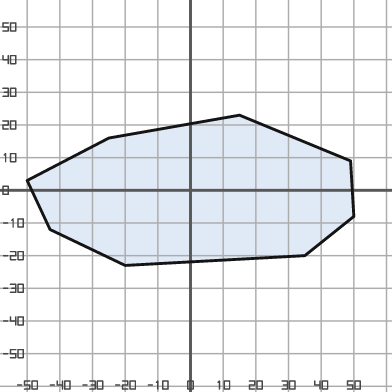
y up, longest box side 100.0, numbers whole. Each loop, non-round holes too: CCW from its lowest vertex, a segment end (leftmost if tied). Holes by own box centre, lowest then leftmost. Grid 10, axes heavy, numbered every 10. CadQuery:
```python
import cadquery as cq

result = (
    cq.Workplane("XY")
    .moveTo(-20.0, -23.0)
    .lineTo(35.0, -20.0)
    .lineTo(50.0, -8.0)
    .lineTo(49.0, 9.0)
    .lineTo(15.0, 23.0)
    .lineTo(-25.0, 16.0)
    .lineTo(-50.0, 3.0)
    .lineTo(-43.0, -12.0)
    .close()
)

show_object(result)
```